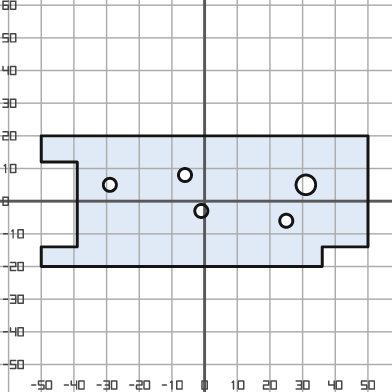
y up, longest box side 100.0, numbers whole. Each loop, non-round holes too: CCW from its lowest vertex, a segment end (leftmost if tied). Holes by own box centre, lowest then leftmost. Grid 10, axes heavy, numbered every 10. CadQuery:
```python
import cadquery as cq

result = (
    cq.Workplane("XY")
    .moveTo(-50.0, -20.0)
    .lineTo(36.0, -20.0)
    .lineTo(36.0, -14.0)
    .lineTo(50.0, -14.0)
    .lineTo(50.0, 20.0)
    .lineTo(-50.0, 20.0)
    .lineTo(-50.0, 12.0)
    .lineTo(-39.0, 12.0)
    .lineTo(-39.0, -14.0)
    .lineTo(-50.0, -14.0)
    .close()
    .moveTo(25.0, -6.0)
    .circle(2.0)
    .moveTo(-1.0, -3.0)
    .circle(2.0)
    .moveTo(-29.0, 5.0)
    .circle(2.0)
    .moveTo(31.0, 5.0)
    .circle(3.0)
    .moveTo(-6.0, 8.0)
    .circle(2.0)
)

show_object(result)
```